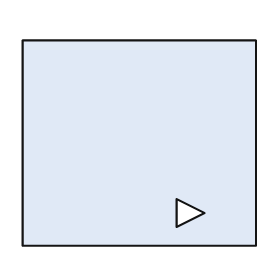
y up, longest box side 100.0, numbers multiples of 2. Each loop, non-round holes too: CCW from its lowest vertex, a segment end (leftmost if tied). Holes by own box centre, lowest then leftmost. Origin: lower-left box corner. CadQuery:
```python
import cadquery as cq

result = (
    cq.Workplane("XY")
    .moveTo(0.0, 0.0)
    .lineTo(100.0, 0.0)
    .lineTo(100.0, 88.0)
    .lineTo(0.0, 88.0)
    .close()
    .moveTo(66.0, 8.0)
    .lineTo(78.0, 14.0)
    .lineTo(66.0, 20.0)
    .close()
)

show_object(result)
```